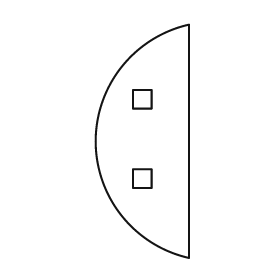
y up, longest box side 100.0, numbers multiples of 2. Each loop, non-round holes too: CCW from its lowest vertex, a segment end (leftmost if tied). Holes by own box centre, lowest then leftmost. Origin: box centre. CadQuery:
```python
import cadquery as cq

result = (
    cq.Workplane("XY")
    .moveTo(20.0, -50.0)
    .lineTo(20.0, 50.0)
    .threePointArc((-20.0, 0.0), (20.0, -50.0))
    .close()
    .moveTo(-4.0, -20.0)
    .lineTo(4.0, -20.0)
    .lineTo(4.0, -12.0)
    .lineTo(-4.0, -12.0)
    .close()
    .moveTo(-4.0, 14.0)
    .lineTo(4.0, 14.0)
    .lineTo(4.0, 22.0)
    .lineTo(-4.0, 22.0)
    .close()
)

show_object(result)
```